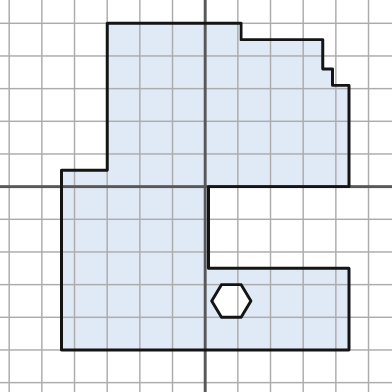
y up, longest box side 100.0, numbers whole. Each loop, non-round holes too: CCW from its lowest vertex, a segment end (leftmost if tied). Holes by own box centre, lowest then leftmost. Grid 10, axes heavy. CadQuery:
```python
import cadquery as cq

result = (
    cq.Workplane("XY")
    .moveTo(-44.0, -50.0)
    .lineTo(44.0, -50.0)
    .lineTo(44.0, -25.0)
    .lineTo(1.0, -25.0)
    .lineTo(1.0, 0.0)
    .lineTo(44.0, 0.0)
    .lineTo(44.0, 31.0)
    .lineTo(39.0, 31.0)
    .lineTo(39.0, 36.0)
    .lineTo(36.0, 36.0)
    .lineTo(36.0, 45.0)
    .lineTo(11.0, 45.0)
    .lineTo(11.0, 50.0)
    .lineTo(-30.0, 50.0)
    .lineTo(-30.0, 5.0)
    .lineTo(-44.0, 5.0)
    .close()
    .moveTo(5.0, -40.0)
    .lineTo(11.0, -40.0)
    .lineTo(14.0, -35.0)
    .lineTo(11.0, -30.0)
    .lineTo(5.0, -30.0)
    .lineTo(2.0, -35.0)
    .close()
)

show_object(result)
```